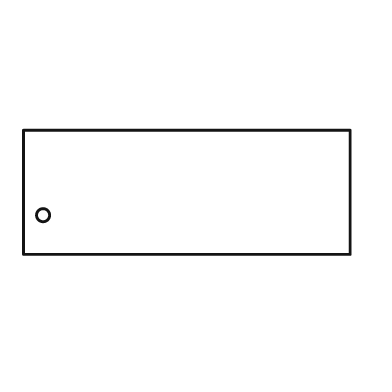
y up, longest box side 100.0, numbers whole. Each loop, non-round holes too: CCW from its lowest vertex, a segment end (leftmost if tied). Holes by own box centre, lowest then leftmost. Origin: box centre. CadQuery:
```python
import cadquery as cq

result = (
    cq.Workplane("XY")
    .moveTo(-50.0, -19.0)
    .lineTo(50.0, -19.0)
    .lineTo(50.0, 19.0)
    .lineTo(-50.0, 19.0)
    .close()
    .moveTo(-44.0, -7.0)
    .circle(2.0)
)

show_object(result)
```